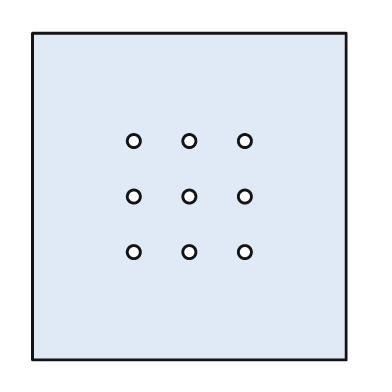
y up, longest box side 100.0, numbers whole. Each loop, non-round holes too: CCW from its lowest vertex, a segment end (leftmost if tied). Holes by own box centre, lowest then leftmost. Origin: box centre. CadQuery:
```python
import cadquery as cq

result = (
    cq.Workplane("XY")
    .moveTo(-48.0, -50.0)
    .lineTo(48.0, -50.0)
    .lineTo(48.0, 50.0)
    .lineTo(-48.0, 50.0)
    .close()
    .moveTo(-17.0, -17.0)
    .circle(2.0)
    .moveTo(0.0, -17.0)
    .circle(2.0)
    .moveTo(17.0, -17.0)
    .circle(2.0)
    .moveTo(-17.0, 0.0)
    .circle(2.0)
    .moveTo(0.0, 0.0)
    .circle(2.0)
    .moveTo(17.0, 0.0)
    .circle(2.0)
    .moveTo(-17.0, 17.0)
    .circle(2.0)
    .moveTo(0.0, 17.0)
    .circle(2.0)
    .moveTo(17.0, 17.0)
    .circle(2.0)
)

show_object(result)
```